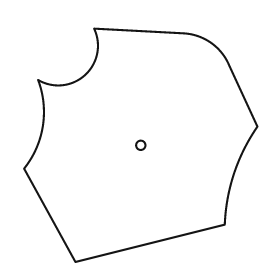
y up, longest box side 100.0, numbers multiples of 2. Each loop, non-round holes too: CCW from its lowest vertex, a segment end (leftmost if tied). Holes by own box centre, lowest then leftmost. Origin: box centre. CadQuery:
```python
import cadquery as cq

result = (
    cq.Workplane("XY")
    .moveTo(-28.0, -50.0)
    .lineTo(36.0, -34.0)
    .threePointArc((40.0, -12.0), (50.0, 8.0))
    .lineTo(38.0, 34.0)
    .threePointArc((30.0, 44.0), (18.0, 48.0))
    .lineTo(-20.0, 50.0)
    .threePointArc((-24.0, 30.0), (-44.0, 28.0))
    .threePointArc((-42.0, 8.0), (-50.0, -10.0))
    .close()
    .moveTo(0.0, 0.0)
    .circle(2.0)
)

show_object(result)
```